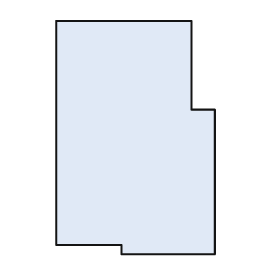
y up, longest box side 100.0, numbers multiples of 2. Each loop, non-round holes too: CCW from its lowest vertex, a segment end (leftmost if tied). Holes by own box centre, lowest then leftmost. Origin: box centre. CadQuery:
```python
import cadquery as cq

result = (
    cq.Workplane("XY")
    .moveTo(-6.0, -50.0)
    .lineTo(34.0, -50.0)
    .lineTo(34.0, 12.0)
    .lineTo(24.0, 12.0)
    .lineTo(24.0, 50.0)
    .lineTo(-34.0, 50.0)
    .lineTo(-34.0, -46.0)
    .lineTo(-6.0, -46.0)
    .close()
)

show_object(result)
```